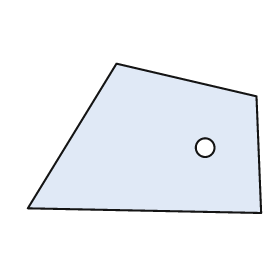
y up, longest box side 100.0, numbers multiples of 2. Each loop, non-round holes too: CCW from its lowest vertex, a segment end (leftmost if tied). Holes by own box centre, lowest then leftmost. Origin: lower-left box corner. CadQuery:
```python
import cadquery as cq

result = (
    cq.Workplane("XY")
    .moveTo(100.0, 0.0)
    .lineTo(98.0, 50.0)
    .lineTo(38.0, 64.0)
    .lineTo(0.0, 2.0)
    .close()
    .moveTo(76.0, 28.0)
    .circle(4.0)
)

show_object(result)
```